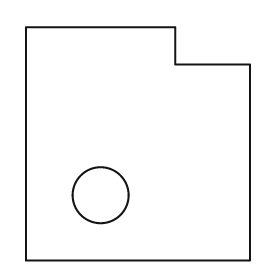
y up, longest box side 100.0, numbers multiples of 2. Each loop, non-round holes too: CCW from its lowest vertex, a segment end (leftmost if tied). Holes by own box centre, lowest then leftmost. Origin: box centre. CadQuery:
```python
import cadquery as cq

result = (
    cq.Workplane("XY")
    .moveTo(-48.0, -50.0)
    .lineTo(48.0, -50.0)
    .lineTo(48.0, 34.0)
    .lineTo(16.0, 34.0)
    .lineTo(16.0, 50.0)
    .lineTo(-48.0, 50.0)
    .close()
    .moveTo(-16.0, -22.0)
    .circle(12.0)
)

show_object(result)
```